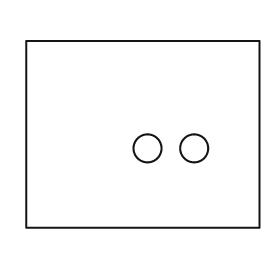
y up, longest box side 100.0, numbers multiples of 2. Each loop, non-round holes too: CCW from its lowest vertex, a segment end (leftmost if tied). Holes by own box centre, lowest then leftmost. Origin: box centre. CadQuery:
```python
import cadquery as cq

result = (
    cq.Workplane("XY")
    .moveTo(-50.0, -40.0)
    .lineTo(50.0, -40.0)
    .lineTo(50.0, 40.0)
    .lineTo(-50.0, 40.0)
    .close()
    .moveTo(2.0, -6.0)
    .circle(6.0)
    .moveTo(22.0, -6.0)
    .circle(6.0)
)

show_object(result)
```